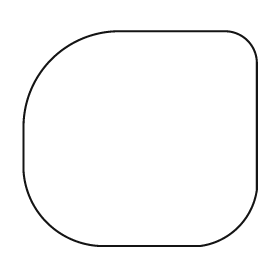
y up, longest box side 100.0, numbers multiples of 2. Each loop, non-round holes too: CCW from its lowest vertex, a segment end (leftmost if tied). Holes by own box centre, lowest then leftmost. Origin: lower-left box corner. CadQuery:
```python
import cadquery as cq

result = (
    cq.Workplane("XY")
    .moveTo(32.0, 0.0)
    .lineTo(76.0, 0.0)
    .threePointArc((92.0, 8.0), (100.0, 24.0))
    .lineTo(100.0, 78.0)
    .threePointArc((96.0, 88.0), (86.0, 92.0))
    .lineTo(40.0, 92.0)
    .threePointArc((12.0, 80.0), (0.0, 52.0))
    .lineTo(0.0, 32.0)
    .threePointArc((10.0, 10.0), (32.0, 0.0))
    .close()
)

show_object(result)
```